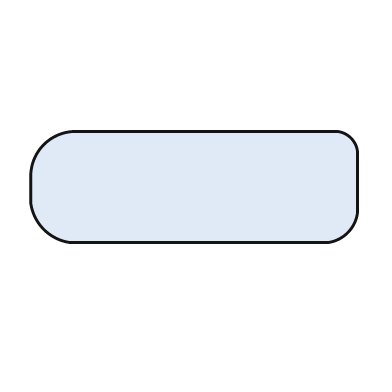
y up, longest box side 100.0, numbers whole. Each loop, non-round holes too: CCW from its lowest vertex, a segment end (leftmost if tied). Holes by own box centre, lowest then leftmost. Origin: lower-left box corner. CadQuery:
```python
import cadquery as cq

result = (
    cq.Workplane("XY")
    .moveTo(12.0, 0.0)
    .lineTo(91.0, 0.0)
    .threePointArc((97.0, 3.0), (100.0, 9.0))
    .lineTo(100.0, 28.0)
    .threePointArc((98.0, 32.0), (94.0, 34.0))
    .lineTo(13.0, 34.0)
    .threePointArc((4.0, 30.0), (0.0, 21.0))
    .lineTo(0.0, 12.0)
    .threePointArc((4.0, 4.0), (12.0, 0.0))
    .close()
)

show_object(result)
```